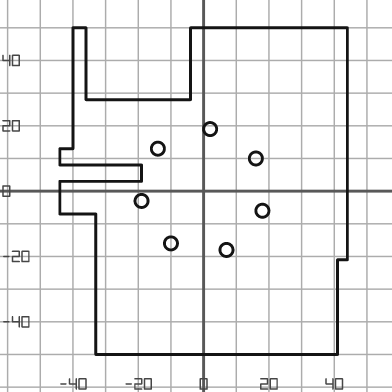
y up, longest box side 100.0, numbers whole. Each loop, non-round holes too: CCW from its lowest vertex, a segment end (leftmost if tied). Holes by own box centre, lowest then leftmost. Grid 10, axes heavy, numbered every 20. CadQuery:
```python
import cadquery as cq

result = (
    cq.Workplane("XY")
    .moveTo(-33.0, -50.0)
    .lineTo(41.0, -50.0)
    .lineTo(41.0, -21.0)
    .lineTo(44.0, -21.0)
    .lineTo(44.0, 50.0)
    .lineTo(-4.0, 50.0)
    .lineTo(-4.0, 28.0)
    .lineTo(-36.0, 28.0)
    .lineTo(-36.0, 50.0)
    .lineTo(-40.0, 50.0)
    .lineTo(-40.0, 13.0)
    .lineTo(-44.0, 13.0)
    .lineTo(-44.0, 8.0)
    .lineTo(-19.0, 8.0)
    .lineTo(-19.0, 3.0)
    .lineTo(-44.0, 3.0)
    .lineTo(-44.0, -7.0)
    .lineTo(-33.0, -7.0)
    .close()
    .moveTo(7.0, -18.0)
    .circle(2.0)
    .moveTo(-10.0, -16.0)
    .circle(2.0)
    .moveTo(18.0, -6.0)
    .circle(2.0)
    .moveTo(-19.0, -3.0)
    .circle(2.0)
    .moveTo(16.0, 10.0)
    .circle(2.0)
    .moveTo(-14.0, 13.0)
    .circle(2.0)
    .moveTo(2.0, 19.0)
    .circle(2.0)
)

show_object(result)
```